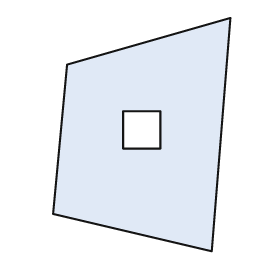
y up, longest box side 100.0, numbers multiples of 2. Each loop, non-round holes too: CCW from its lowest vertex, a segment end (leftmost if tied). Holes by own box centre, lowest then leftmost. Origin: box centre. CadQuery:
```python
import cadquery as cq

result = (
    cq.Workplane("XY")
    .moveTo(30.0, -50.0)
    .lineTo(38.0, 50.0)
    .lineTo(-32.0, 30.0)
    .lineTo(-38.0, -34.0)
    .close()
    .moveTo(-8.0, -6.0)
    .lineTo(8.0, -6.0)
    .lineTo(8.0, 10.0)
    .lineTo(-8.0, 10.0)
    .close()
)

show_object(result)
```